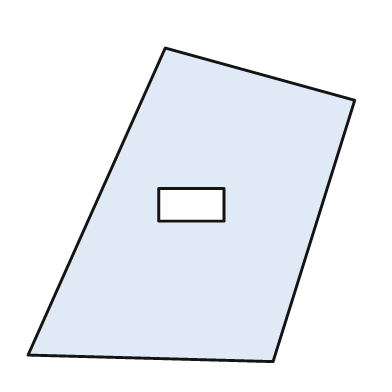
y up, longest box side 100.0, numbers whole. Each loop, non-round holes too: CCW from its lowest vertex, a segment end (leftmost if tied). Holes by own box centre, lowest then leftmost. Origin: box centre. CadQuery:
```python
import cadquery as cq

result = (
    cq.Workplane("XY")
    .moveTo(25.0, -48.0)
    .lineTo(50.0, 32.0)
    .lineTo(-8.0, 48.0)
    .lineTo(-50.0, -46.0)
    .close()
    .moveTo(-10.0, -5.0)
    .lineTo(10.0, -5.0)
    .lineTo(10.0, 5.0)
    .lineTo(-10.0, 5.0)
    .close()
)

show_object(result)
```